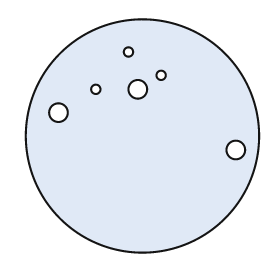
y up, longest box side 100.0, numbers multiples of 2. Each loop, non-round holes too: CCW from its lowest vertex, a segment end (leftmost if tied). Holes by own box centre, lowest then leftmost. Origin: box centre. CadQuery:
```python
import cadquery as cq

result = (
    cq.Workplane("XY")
    .moveTo(0.0, 0.0)
    .circle(50.0)
    .moveTo(40.0, -6.0)
    .circle(4.0)
    .moveTo(-36.0, 10.0)
    .circle(4.0)
    .moveTo(-20.0, 20.0)
    .circle(2.0)
    .moveTo(-2.0, 20.0)
    .circle(4.0)
    .moveTo(8.0, 26.0)
    .circle(2.0)
    .moveTo(-6.0, 36.0)
    .circle(2.0)
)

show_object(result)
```